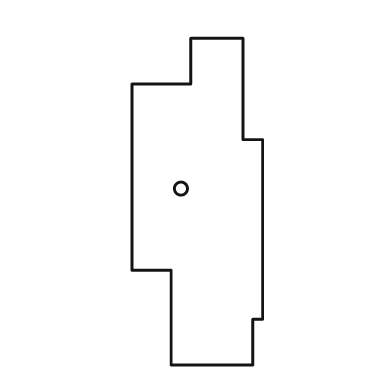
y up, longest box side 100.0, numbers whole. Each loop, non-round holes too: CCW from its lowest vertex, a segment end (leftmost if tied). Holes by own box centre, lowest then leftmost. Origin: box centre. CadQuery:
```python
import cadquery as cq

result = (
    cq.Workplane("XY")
    .moveTo(-8.0, -50.0)
    .lineTo(17.0, -50.0)
    .lineTo(17.0, -36.0)
    .lineTo(20.0, -36.0)
    .lineTo(20.0, 19.0)
    .lineTo(14.0, 19.0)
    .lineTo(14.0, 50.0)
    .lineTo(-2.0, 50.0)
    .lineTo(-2.0, 36.0)
    .lineTo(-20.0, 36.0)
    .lineTo(-20.0, -21.0)
    .lineTo(-8.0, -21.0)
    .close()
    .moveTo(-5.0, 4.0)
    .circle(2.0)
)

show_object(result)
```